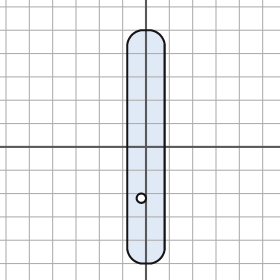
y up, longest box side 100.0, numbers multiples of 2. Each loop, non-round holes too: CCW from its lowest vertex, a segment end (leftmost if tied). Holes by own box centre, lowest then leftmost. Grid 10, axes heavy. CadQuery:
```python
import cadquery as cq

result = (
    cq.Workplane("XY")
    .moveTo(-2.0, -50.0)
    .lineTo(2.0, -50.0)
    .threePointArc((6.0, -48.0), (8.0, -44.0))
    .lineTo(8.0, 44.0)
    .threePointArc((6.0, 48.0), (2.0, 50.0))
    .lineTo(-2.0, 50.0)
    .threePointArc((-6.0, 48.0), (-8.0, 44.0))
    .lineTo(-8.0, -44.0)
    .threePointArc((-6.0, -48.0), (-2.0, -50.0))
    .close()
    .moveTo(-2.0, -22.0)
    .circle(2.0)
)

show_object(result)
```